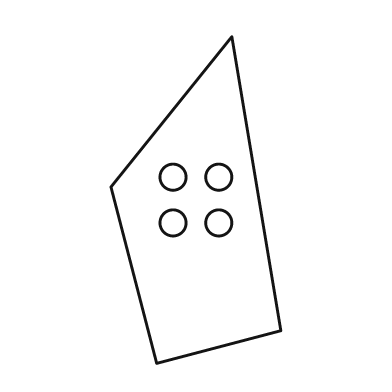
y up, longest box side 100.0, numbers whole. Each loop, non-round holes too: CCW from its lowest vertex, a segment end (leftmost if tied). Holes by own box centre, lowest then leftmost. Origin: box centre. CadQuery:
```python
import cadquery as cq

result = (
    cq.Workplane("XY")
    .moveTo(-12.0, -50.0)
    .lineTo(26.0, -40.0)
    .lineTo(11.0, 50.0)
    .lineTo(-26.0, 4.0)
    .close()
    .moveTo(-7.0, -7.0)
    .circle(4.0)
    .moveTo(7.0, -7.0)
    .circle(4.0)
    .moveTo(-7.0, 7.0)
    .circle(4.0)
    .moveTo(7.0, 7.0)
    .circle(4.0)
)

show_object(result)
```